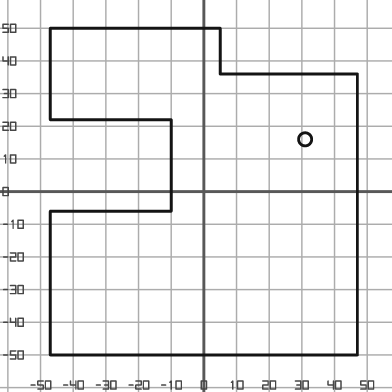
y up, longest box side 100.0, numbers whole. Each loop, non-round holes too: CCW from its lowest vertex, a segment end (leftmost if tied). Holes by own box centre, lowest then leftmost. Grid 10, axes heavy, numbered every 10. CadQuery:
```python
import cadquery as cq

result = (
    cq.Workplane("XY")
    .moveTo(-47.0, -50.0)
    .lineTo(47.0, -50.0)
    .lineTo(47.0, 36.0)
    .lineTo(5.0, 36.0)
    .lineTo(5.0, 50.0)
    .lineTo(-47.0, 50.0)
    .lineTo(-47.0, 22.0)
    .lineTo(-10.0, 22.0)
    .lineTo(-10.0, -6.0)
    .lineTo(-47.0, -6.0)
    .close()
    .moveTo(31.0, 16.0)
    .circle(2.0)
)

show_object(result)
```